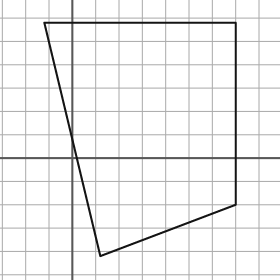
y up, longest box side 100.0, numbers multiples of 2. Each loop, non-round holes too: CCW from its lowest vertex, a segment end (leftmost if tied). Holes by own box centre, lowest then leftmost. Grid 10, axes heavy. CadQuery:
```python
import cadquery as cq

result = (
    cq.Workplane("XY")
    .moveTo(12.0, -42.0)
    .lineTo(70.0, -20.0)
    .lineTo(70.0, 58.0)
    .lineTo(-12.0, 58.0)
    .close()
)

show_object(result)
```